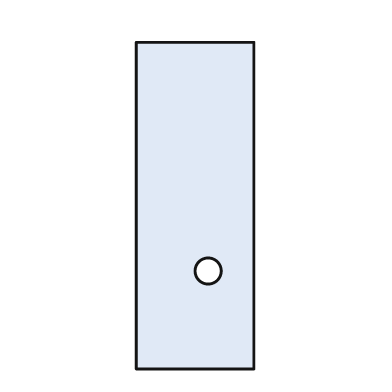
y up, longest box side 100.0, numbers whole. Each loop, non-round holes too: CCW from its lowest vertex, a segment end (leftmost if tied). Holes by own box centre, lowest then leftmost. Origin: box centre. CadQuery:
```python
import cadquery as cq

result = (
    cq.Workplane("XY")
    .moveTo(-18.0, -50.0)
    .lineTo(18.0, -50.0)
    .lineTo(18.0, 50.0)
    .lineTo(-18.0, 50.0)
    .close()
    .moveTo(4.0, -20.0)
    .circle(4.0)
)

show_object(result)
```